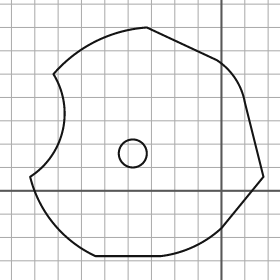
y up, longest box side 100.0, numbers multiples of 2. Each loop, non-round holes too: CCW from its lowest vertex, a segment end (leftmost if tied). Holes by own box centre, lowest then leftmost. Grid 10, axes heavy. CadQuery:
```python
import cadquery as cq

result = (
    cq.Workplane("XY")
    .moveTo(-54.0, -28.0)
    .lineTo(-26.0, -28.0)
    .threePointArc((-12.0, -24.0), (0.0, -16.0))
    .lineTo(18.0, 6.0)
    .lineTo(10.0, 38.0)
    .threePointArc((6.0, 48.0), (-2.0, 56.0))
    .lineTo(-32.0, 70.0)
    .threePointArc((-54.0, 64.0), (-72.0, 50.0))
    .threePointArc((-68.0, 26.0), (-82.0, 6.0))
    .threePointArc((-72.0, -14.0), (-54.0, -28.0))
    .close()
    .moveTo(-38.0, 16.0)
    .circle(6.0)
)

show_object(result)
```